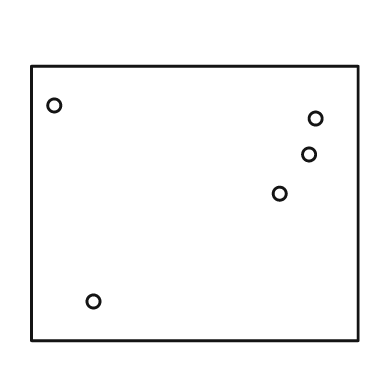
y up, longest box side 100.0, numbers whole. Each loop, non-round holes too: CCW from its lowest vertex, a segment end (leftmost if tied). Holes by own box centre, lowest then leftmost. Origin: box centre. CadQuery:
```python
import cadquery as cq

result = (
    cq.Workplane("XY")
    .moveTo(-50.0, -42.0)
    .lineTo(50.0, -42.0)
    .lineTo(50.0, 42.0)
    .lineTo(-50.0, 42.0)
    .close()
    .moveTo(-31.0, -30.0)
    .circle(2.0)
    .moveTo(26.0, 3.0)
    .circle(2.0)
    .moveTo(35.0, 15.0)
    .circle(2.0)
    .moveTo(37.0, 26.0)
    .circle(2.0)
    .moveTo(-43.0, 30.0)
    .circle(2.0)
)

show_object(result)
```